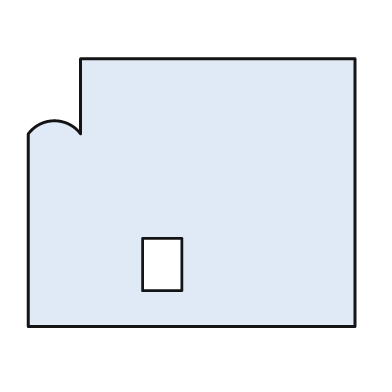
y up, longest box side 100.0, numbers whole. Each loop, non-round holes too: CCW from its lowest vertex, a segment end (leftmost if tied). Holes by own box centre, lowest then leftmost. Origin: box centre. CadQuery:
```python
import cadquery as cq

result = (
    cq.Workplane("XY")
    .moveTo(-50.0, -41.0)
    .lineTo(50.0, -41.0)
    .lineTo(50.0, 41.0)
    .lineTo(-34.0, 41.0)
    .lineTo(-34.0, 18.0)
    .threePointArc((-42.0, 22.0), (-50.0, 18.0))
    .close()
    .moveTo(-15.0, -30.0)
    .lineTo(-3.0, -30.0)
    .lineTo(-3.0, -14.0)
    .lineTo(-15.0, -14.0)
    .close()
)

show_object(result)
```